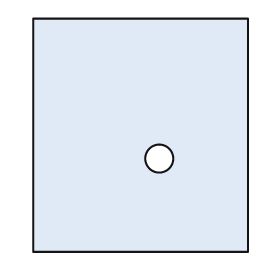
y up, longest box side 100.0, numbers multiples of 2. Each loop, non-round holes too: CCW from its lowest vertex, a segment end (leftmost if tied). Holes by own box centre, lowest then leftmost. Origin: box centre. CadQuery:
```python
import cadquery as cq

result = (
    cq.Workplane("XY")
    .moveTo(-46.0, -50.0)
    .lineTo(46.0, -50.0)
    .lineTo(46.0, 50.0)
    .lineTo(-46.0, 50.0)
    .close()
    .moveTo(8.0, -10.0)
    .circle(6.0)
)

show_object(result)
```